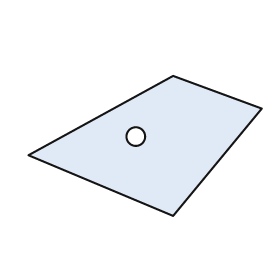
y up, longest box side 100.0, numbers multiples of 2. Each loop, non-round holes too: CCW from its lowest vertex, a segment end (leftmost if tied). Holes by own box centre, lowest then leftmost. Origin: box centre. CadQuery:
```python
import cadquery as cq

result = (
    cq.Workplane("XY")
    .moveTo(12.0, -30.0)
    .lineTo(50.0, 16.0)
    .lineTo(12.0, 30.0)
    .lineTo(-50.0, -4.0)
    .close()
    .moveTo(-4.0, 4.0)
    .circle(4.0)
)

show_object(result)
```